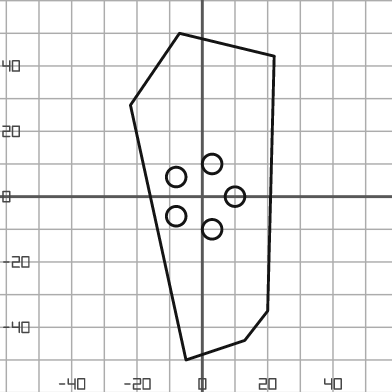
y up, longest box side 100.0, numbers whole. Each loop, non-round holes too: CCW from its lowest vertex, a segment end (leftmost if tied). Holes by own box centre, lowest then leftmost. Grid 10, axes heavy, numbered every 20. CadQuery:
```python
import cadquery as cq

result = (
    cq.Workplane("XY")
    .moveTo(-5.0, -50.0)
    .lineTo(13.0, -44.0)
    .lineTo(20.0, -35.0)
    .lineTo(22.0, 43.0)
    .lineTo(-7.0, 50.0)
    .lineTo(-22.0, 28.0)
    .close()
    .moveTo(3.0, -10.0)
    .circle(3.0)
    .moveTo(-8.0, -6.0)
    .circle(3.0)
    .moveTo(10.0, 0.0)
    .circle(3.0)
    .moveTo(-8.0, 6.0)
    .circle(3.0)
    .moveTo(3.0, 10.0)
    .circle(3.0)
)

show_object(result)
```